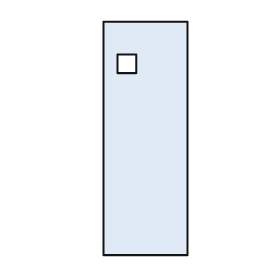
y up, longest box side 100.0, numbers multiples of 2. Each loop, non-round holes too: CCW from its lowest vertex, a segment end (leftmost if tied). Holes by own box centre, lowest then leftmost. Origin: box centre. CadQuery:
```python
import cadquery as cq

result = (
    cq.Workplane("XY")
    .moveTo(-18.0, -50.0)
    .lineTo(18.0, -50.0)
    .lineTo(18.0, 50.0)
    .lineTo(-18.0, 50.0)
    .close()
    .moveTo(-12.0, 28.0)
    .lineTo(-4.0, 28.0)
    .lineTo(-4.0, 36.0)
    .lineTo(-12.0, 36.0)
    .close()
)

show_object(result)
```